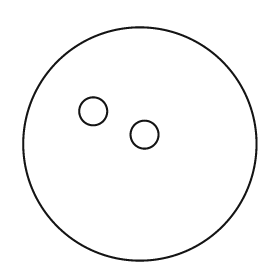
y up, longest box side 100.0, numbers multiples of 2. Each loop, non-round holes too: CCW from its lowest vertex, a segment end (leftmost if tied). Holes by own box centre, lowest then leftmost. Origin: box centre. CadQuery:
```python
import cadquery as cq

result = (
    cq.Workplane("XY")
    .moveTo(0.0, 0.0)
    .circle(50.0)
    .moveTo(2.0, 4.0)
    .circle(6.0)
    .moveTo(-20.0, 14.0)
    .circle(6.0)
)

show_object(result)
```